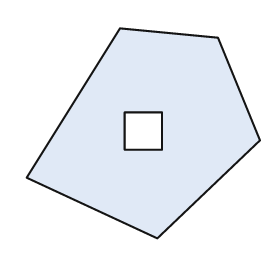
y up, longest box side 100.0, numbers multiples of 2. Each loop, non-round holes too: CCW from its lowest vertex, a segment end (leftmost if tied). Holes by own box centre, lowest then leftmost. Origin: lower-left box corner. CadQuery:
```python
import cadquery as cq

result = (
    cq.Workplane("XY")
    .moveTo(56.0, 0.0)
    .lineTo(100.0, 42.0)
    .lineTo(82.0, 86.0)
    .lineTo(40.0, 90.0)
    .lineTo(0.0, 26.0)
    .close()
    .moveTo(42.0, 38.0)
    .lineTo(58.0, 38.0)
    .lineTo(58.0, 54.0)
    .lineTo(42.0, 54.0)
    .close()
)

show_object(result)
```